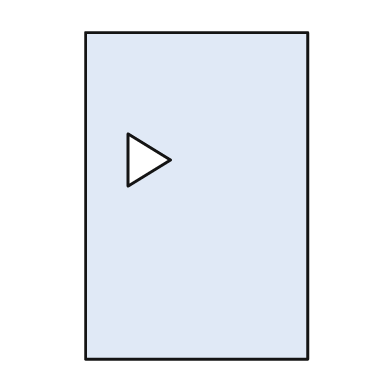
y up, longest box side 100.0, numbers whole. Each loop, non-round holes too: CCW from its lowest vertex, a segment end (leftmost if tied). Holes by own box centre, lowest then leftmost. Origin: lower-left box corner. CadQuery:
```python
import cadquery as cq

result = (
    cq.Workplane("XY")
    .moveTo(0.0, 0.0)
    .lineTo(68.0, 0.0)
    .lineTo(68.0, 100.0)
    .lineTo(0.0, 100.0)
    .close()
    .moveTo(13.0, 53.0)
    .lineTo(26.0, 61.0)
    .lineTo(13.0, 69.0)
    .close()
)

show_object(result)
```